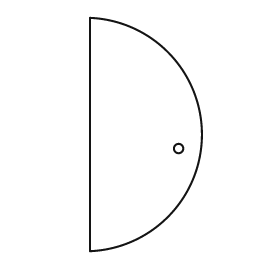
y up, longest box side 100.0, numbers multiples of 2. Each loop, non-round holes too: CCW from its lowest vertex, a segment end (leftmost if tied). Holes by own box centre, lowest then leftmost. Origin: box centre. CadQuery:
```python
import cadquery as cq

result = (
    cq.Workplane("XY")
    .moveTo(-24.0, -50.0)
    .threePointArc((24.0, 0.0), (-24.0, 50.0))
    .close()
    .moveTo(14.0, -6.0)
    .circle(2.0)
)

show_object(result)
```